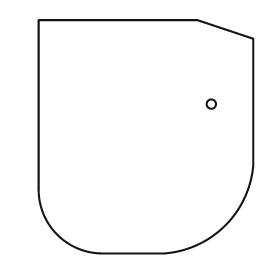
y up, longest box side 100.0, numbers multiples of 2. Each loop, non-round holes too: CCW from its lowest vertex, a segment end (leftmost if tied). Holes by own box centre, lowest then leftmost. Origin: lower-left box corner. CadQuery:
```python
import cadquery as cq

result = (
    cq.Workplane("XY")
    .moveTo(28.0, 0.0)
    .lineTo(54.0, 0.0)
    .threePointArc((80.0, 12.0), (92.0, 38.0))
    .lineTo(92.0, 92.0)
    .lineTo(68.0, 100.0)
    .lineTo(0.0, 100.0)
    .lineTo(0.0, 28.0)
    .threePointArc((8.0, 8.0), (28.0, 0.0))
    .close()
    .moveTo(74.0, 64.0)
    .circle(2.0)
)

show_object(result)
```